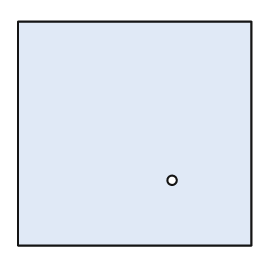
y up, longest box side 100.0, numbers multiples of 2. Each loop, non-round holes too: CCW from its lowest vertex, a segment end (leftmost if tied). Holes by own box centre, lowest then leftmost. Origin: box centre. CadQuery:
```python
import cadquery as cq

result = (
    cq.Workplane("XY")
    .moveTo(-50.0, -48.0)
    .lineTo(50.0, -48.0)
    .lineTo(50.0, 48.0)
    .lineTo(-50.0, 48.0)
    .close()
    .moveTo(16.0, -20.0)
    .circle(2.0)
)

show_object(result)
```